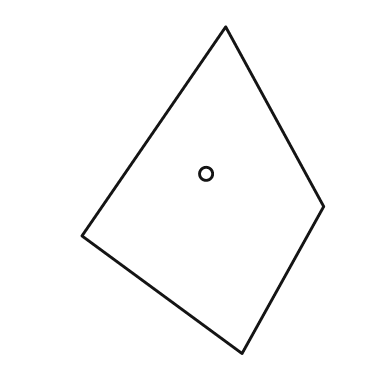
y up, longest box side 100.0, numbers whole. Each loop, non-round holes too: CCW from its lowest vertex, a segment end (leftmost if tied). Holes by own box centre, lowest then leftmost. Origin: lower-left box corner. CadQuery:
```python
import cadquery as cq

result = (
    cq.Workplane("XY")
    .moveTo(49.0, 0.0)
    .lineTo(74.0, 45.0)
    .lineTo(44.0, 100.0)
    .lineTo(0.0, 36.0)
    .close()
    .moveTo(38.0, 55.0)
    .circle(2.0)
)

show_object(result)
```